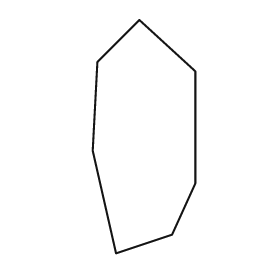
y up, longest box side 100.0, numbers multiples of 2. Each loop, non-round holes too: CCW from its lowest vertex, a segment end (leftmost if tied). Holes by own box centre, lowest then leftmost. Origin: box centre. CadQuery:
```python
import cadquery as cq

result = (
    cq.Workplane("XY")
    .moveTo(-12.0, -50.0)
    .lineTo(12.0, -42.0)
    .lineTo(22.0, -20.0)
    .lineTo(22.0, 28.0)
    .lineTo(-2.0, 50.0)
    .lineTo(-20.0, 32.0)
    .lineTo(-22.0, -6.0)
    .close()
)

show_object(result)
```